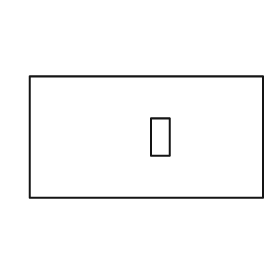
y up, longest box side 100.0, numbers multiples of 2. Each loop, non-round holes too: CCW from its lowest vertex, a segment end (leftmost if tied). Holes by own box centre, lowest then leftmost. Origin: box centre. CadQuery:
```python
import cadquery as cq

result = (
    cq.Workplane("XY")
    .moveTo(-50.0, -26.0)
    .lineTo(50.0, -26.0)
    .lineTo(50.0, 26.0)
    .lineTo(-50.0, 26.0)
    .close()
    .moveTo(2.0, -8.0)
    .lineTo(10.0, -8.0)
    .lineTo(10.0, 8.0)
    .lineTo(2.0, 8.0)
    .close()
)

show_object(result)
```